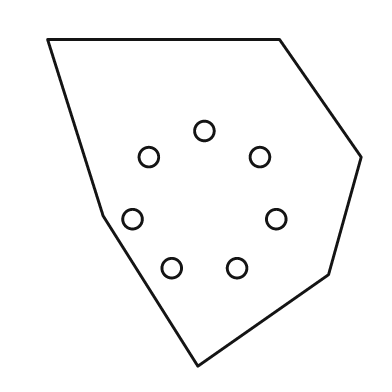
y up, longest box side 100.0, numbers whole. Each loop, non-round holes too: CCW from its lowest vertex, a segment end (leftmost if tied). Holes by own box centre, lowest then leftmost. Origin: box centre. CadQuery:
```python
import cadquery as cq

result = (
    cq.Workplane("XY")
    .moveTo(-2.0, -50.0)
    .lineTo(38.0, -22.0)
    .lineTo(48.0, 14.0)
    .lineTo(23.0, 50.0)
    .lineTo(-48.0, 50.0)
    .lineTo(-31.0, -4.0)
    .close()
    .moveTo(-10.0, -20.0)
    .circle(3.0)
    .moveTo(10.0, -20.0)
    .circle(3.0)
    .moveTo(-22.0, -5.0)
    .circle(3.0)
    .moveTo(22.0, -5.0)
    .circle(3.0)
    .moveTo(-17.0, 14.0)
    .circle(3.0)
    .moveTo(17.0, 14.0)
    .circle(3.0)
    .moveTo(0.0, 22.0)
    .circle(3.0)
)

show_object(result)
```